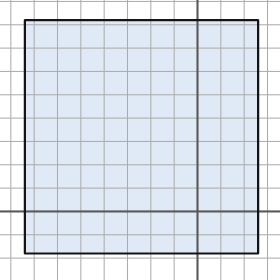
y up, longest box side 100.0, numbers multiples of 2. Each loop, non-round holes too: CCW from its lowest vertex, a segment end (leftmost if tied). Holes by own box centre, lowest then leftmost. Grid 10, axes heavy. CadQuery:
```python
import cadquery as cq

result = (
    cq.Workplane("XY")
    .moveTo(-74.0, -18.0)
    .lineTo(26.0, -18.0)
    .lineTo(26.0, 82.0)
    .lineTo(-74.0, 82.0)
    .close()
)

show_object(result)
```